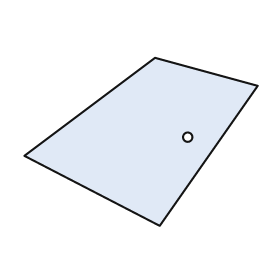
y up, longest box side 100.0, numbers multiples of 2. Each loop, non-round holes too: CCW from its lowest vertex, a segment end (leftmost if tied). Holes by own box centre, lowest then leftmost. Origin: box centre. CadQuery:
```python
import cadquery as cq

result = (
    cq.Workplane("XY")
    .moveTo(8.0, -36.0)
    .lineTo(50.0, 24.0)
    .lineTo(6.0, 36.0)
    .lineTo(-50.0, -6.0)
    .close()
    .moveTo(20.0, 2.0)
    .circle(2.0)
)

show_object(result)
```